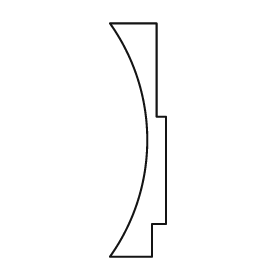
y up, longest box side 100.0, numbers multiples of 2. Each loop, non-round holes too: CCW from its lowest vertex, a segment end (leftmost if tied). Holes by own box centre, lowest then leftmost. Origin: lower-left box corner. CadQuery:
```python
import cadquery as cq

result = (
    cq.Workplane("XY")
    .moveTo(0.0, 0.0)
    .lineTo(18.0, 0.0)
    .lineTo(18.0, 14.0)
    .lineTo(24.0, 14.0)
    .lineTo(24.0, 60.0)
    .lineTo(20.0, 60.0)
    .lineTo(20.0, 100.0)
    .lineTo(0.0, 100.0)
    .threePointArc((16.0, 50.0), (0.0, 0.0))
    .close()
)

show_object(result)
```